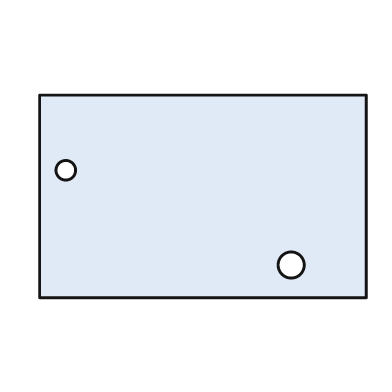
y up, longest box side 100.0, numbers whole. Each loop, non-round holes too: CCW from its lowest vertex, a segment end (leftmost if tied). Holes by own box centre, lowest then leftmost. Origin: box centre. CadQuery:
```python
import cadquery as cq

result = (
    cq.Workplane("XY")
    .moveTo(-50.0, -31.0)
    .lineTo(50.0, -31.0)
    .lineTo(50.0, 31.0)
    .lineTo(-50.0, 31.0)
    .close()
    .moveTo(27.0, -21.0)
    .circle(4.0)
    .moveTo(-42.0, 8.0)
    .circle(3.0)
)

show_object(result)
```